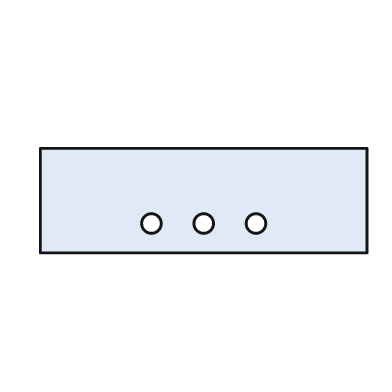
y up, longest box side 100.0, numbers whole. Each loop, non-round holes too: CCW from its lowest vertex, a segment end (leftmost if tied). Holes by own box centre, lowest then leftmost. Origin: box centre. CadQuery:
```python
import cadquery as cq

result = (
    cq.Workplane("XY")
    .moveTo(-50.0, -16.0)
    .lineTo(50.0, -16.0)
    .lineTo(50.0, 16.0)
    .lineTo(-50.0, 16.0)
    .close()
    .moveTo(-16.0, -7.0)
    .circle(3.0)
    .moveTo(0.0, -7.0)
    .circle(3.0)
    .moveTo(16.0, -7.0)
    .circle(3.0)
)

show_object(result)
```